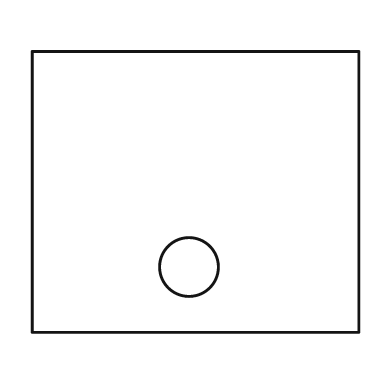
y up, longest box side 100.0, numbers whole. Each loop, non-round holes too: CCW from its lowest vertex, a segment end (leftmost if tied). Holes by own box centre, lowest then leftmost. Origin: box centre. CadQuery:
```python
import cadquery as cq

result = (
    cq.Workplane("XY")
    .moveTo(-50.0, -43.0)
    .lineTo(50.0, -43.0)
    .lineTo(50.0, 43.0)
    .lineTo(-50.0, 43.0)
    .close()
    .moveTo(-2.0, -23.0)
    .circle(9.0)
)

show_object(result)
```